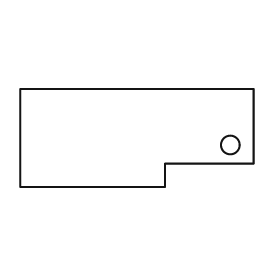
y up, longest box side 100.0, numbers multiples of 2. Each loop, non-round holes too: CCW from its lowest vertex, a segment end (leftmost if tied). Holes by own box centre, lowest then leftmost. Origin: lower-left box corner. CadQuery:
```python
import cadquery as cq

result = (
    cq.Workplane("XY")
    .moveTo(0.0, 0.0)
    .lineTo(62.0, 0.0)
    .lineTo(62.0, 10.0)
    .lineTo(100.0, 10.0)
    .lineTo(100.0, 42.0)
    .lineTo(0.0, 42.0)
    .close()
    .moveTo(90.0, 18.0)
    .circle(4.0)
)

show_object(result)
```